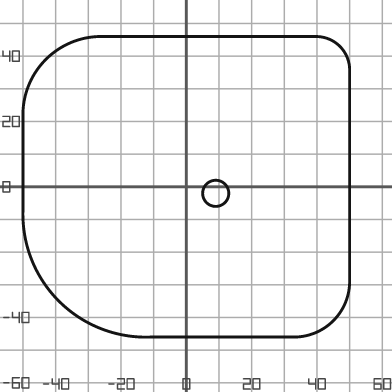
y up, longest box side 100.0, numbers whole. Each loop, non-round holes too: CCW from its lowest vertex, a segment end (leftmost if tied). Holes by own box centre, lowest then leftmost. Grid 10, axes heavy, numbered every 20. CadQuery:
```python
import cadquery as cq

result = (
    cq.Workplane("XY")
    .moveTo(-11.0, -46.0)
    .lineTo(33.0, -46.0)
    .threePointArc((45.0, -41.0), (50.0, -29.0))
    .lineTo(50.0, 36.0)
    .threePointArc((47.0, 43.0), (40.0, 46.0))
    .lineTo(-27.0, 46.0)
    .threePointArc((-43.0, 39.0), (-50.0, 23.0))
    .lineTo(-50.0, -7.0)
    .threePointArc((-39.0, -35.0), (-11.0, -46.0))
    .close()
    .moveTo(9.0, -2.0)
    .circle(4.0)
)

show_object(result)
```